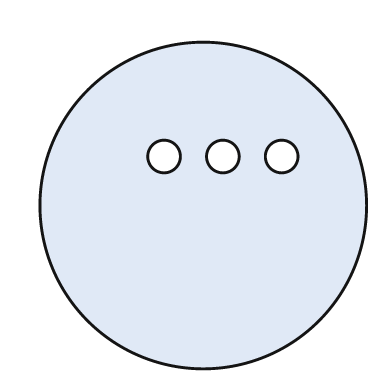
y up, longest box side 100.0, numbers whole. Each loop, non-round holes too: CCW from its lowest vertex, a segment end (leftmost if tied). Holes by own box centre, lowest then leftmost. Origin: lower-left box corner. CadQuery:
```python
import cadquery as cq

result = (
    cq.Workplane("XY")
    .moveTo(50.0, 50.0)
    .circle(50.0)
    .moveTo(38.0, 65.0)
    .circle(5.0)
    .moveTo(56.0, 65.0)
    .circle(5.0)
    .moveTo(74.0, 65.0)
    .circle(5.0)
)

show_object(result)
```